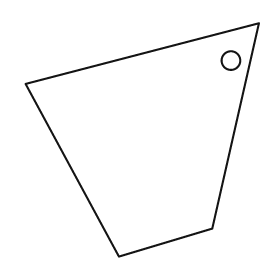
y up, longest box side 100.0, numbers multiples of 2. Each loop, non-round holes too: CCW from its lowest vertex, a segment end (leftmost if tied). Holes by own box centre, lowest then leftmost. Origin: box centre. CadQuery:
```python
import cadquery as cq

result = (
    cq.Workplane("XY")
    .moveTo(-10.0, -50.0)
    .lineTo(30.0, -38.0)
    .lineTo(50.0, 50.0)
    .lineTo(-50.0, 24.0)
    .close()
    .moveTo(38.0, 34.0)
    .circle(4.0)
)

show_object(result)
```